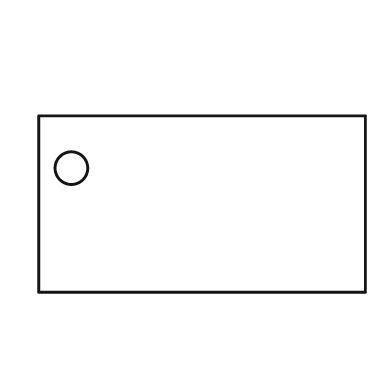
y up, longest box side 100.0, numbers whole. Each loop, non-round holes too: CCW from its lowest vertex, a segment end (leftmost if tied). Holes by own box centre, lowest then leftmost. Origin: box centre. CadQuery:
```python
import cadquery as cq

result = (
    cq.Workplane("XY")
    .moveTo(-50.0, -27.0)
    .lineTo(50.0, -27.0)
    .lineTo(50.0, 27.0)
    .lineTo(-50.0, 27.0)
    .close()
    .moveTo(-40.0, 11.0)
    .circle(5.0)
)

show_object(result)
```